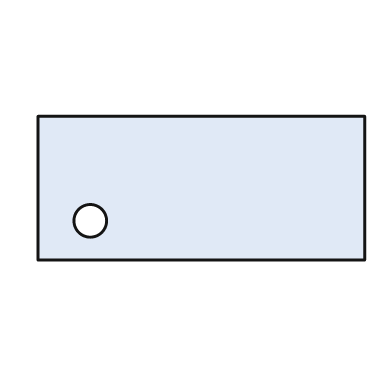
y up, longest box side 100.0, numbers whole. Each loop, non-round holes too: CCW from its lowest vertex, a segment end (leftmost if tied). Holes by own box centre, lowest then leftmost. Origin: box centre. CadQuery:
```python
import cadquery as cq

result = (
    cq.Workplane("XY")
    .moveTo(-50.0, -22.0)
    .lineTo(50.0, -22.0)
    .lineTo(50.0, 22.0)
    .lineTo(-50.0, 22.0)
    .close()
    .moveTo(-34.0, -10.0)
    .circle(5.0)
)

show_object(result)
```